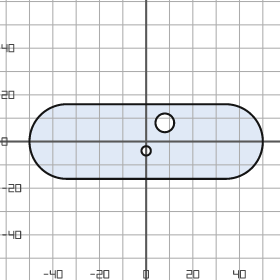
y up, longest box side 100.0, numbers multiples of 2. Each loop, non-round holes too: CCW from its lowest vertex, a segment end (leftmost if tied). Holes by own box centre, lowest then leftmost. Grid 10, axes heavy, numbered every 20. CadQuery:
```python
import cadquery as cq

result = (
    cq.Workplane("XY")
    .moveTo(-34.0, -16.0)
    .lineTo(34.0, -16.0)
    .threePointArc((50.0, 0.0), (34.0, 16.0))
    .lineTo(-34.0, 16.0)
    .threePointArc((-50.0, 0.0), (-34.0, -16.0))
    .close()
    .moveTo(0.0, -4.0)
    .circle(2.0)
    .moveTo(8.0, 8.0)
    .circle(4.0)
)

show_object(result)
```